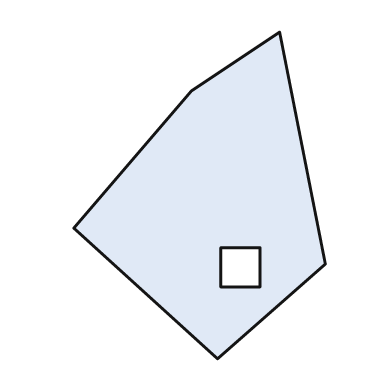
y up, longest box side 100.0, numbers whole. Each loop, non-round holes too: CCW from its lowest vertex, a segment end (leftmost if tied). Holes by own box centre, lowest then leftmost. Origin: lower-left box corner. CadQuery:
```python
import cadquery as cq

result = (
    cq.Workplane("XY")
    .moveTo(44.0, 0.0)
    .lineTo(77.0, 29.0)
    .lineTo(63.0, 100.0)
    .lineTo(36.0, 82.0)
    .lineTo(0.0, 40.0)
    .close()
    .moveTo(45.0, 22.0)
    .lineTo(57.0, 22.0)
    .lineTo(57.0, 34.0)
    .lineTo(45.0, 34.0)
    .close()
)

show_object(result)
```